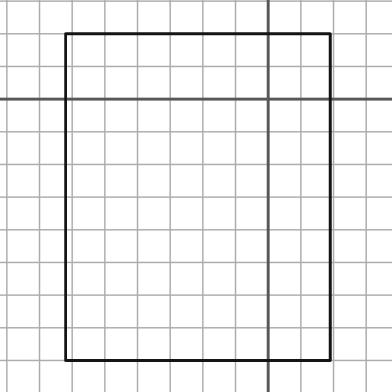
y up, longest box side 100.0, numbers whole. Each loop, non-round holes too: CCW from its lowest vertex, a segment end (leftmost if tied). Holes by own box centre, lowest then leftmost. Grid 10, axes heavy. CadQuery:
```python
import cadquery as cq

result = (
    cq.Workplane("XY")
    .moveTo(-62.0, -80.0)
    .lineTo(19.0, -80.0)
    .lineTo(19.0, 20.0)
    .lineTo(-62.0, 20.0)
    .close()
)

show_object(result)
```